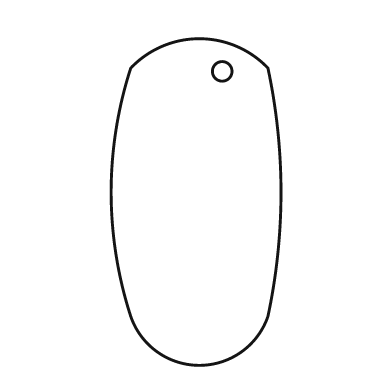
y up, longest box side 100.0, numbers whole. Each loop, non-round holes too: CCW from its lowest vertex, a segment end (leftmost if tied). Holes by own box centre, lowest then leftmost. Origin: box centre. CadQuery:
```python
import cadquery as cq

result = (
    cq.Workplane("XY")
    .moveTo(-20.0, -35.0)
    .threePointArc((1.0, -50.0), (22.0, -35.0))
    .threePointArc((26.0, 3.0), (22.0, 41.0))
    .threePointArc((1.0, 50.0), (-20.0, 41.0))
    .threePointArc((-26.0, 3.0), (-20.0, -35.0))
    .close()
    .moveTo(8.0, 40.0)
    .circle(3.0)
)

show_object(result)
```